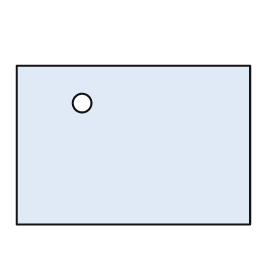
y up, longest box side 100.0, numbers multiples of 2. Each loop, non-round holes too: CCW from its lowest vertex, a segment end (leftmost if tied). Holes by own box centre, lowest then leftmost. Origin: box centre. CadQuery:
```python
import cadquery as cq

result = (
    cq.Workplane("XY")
    .moveTo(-50.0, -34.0)
    .lineTo(50.0, -34.0)
    .lineTo(50.0, 34.0)
    .lineTo(-50.0, 34.0)
    .close()
    .moveTo(-22.0, 18.0)
    .circle(4.0)
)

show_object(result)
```